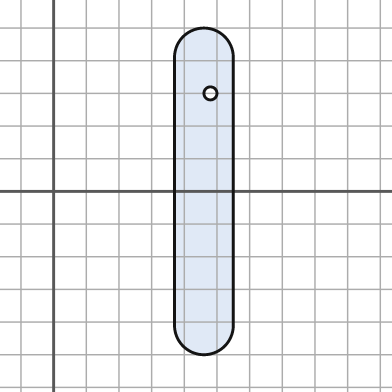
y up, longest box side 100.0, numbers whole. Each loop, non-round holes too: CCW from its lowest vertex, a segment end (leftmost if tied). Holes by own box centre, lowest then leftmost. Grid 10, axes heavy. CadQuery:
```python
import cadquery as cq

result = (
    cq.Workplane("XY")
    .moveTo(37.0, -41.0)
    .threePointArc((46.0, -50.0), (55.0, -41.0))
    .lineTo(55.0, 41.0)
    .threePointArc((46.0, 50.0), (37.0, 41.0))
    .close()
    .moveTo(48.0, 30.0)
    .circle(2.0)
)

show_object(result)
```